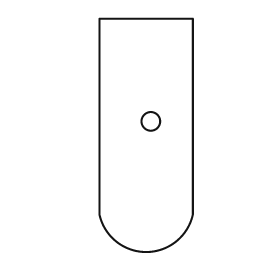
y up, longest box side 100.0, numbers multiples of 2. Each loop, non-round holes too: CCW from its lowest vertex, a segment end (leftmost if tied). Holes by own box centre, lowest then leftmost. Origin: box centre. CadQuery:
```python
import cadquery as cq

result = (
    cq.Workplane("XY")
    .moveTo(-20.0, -34.0)
    .threePointArc((0.0, -50.0), (20.0, -34.0))
    .lineTo(20.0, 50.0)
    .lineTo(-20.0, 50.0)
    .close()
    .moveTo(2.0, 6.0)
    .circle(4.0)
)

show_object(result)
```